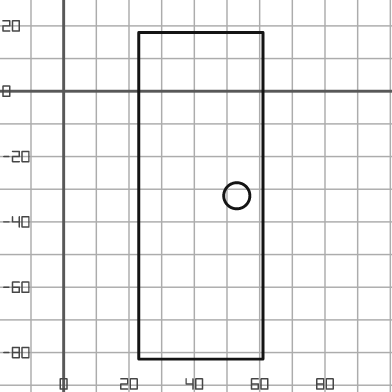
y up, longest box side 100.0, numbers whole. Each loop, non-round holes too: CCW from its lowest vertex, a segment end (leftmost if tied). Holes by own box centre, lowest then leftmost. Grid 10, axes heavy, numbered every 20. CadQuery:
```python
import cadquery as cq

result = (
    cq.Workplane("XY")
    .moveTo(23.0, -82.0)
    .lineTo(61.0, -82.0)
    .lineTo(61.0, 18.0)
    .lineTo(23.0, 18.0)
    .close()
    .moveTo(53.0, -32.0)
    .circle(4.0)
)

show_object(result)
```